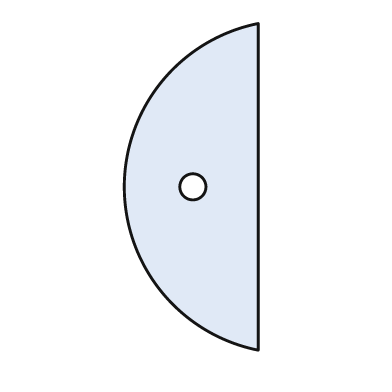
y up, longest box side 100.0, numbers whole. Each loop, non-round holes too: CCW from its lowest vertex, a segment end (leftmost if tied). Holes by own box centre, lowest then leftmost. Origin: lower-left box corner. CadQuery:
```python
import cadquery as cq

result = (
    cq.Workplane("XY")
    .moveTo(41.0, 0.0)
    .lineTo(41.0, 100.0)
    .threePointArc((0.0, 50.0), (41.0, 0.0))
    .close()
    .moveTo(21.0, 50.0)
    .circle(4.0)
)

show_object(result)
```